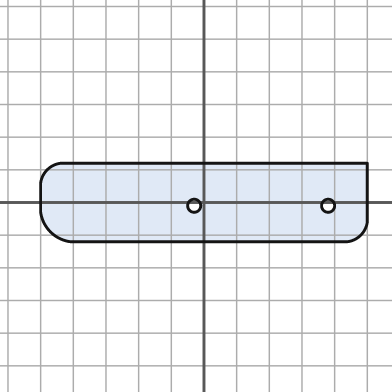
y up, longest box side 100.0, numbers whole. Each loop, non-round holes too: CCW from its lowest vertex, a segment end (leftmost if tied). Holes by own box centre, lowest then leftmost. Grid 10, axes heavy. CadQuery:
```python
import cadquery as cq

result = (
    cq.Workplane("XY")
    .moveTo(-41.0, -12.0)
    .lineTo(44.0, -12.0)
    .threePointArc((48.0, -10.0), (50.0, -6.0))
    .lineTo(50.0, 12.0)
    .lineTo(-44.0, 12.0)
    .threePointArc((-48.0, 10.0), (-50.0, 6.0))
    .lineTo(-50.0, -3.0)
    .threePointArc((-47.0, -9.0), (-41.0, -12.0))
    .close()
    .moveTo(-3.0, -1.0)
    .circle(2.0)
    .moveTo(38.0, -1.0)
    .circle(2.0)
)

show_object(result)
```